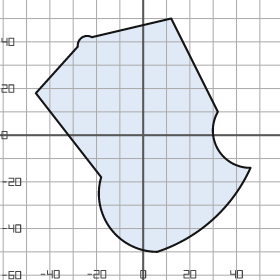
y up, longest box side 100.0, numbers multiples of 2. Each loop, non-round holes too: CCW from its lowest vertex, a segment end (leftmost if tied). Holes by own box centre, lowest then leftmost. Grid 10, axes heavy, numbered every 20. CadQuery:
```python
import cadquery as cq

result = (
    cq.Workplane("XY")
    .moveTo(6.0, -50.0)
    .threePointArc((30.0, -36.0), (46.0, -14.0))
    .threePointArc((32.0, -6.0), (32.0, 10.0))
    .lineTo(12.0, 50.0)
    .lineTo(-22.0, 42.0)
    .threePointArc((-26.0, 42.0), (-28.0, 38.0))
    .lineTo(-46.0, 18.0)
    .lineTo(-18.0, -18.0)
    .threePointArc((-14.0, -40.0), (6.0, -50.0))
    .close()
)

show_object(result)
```